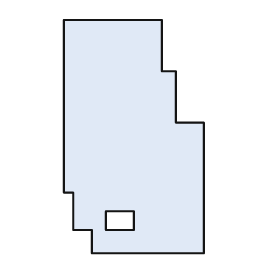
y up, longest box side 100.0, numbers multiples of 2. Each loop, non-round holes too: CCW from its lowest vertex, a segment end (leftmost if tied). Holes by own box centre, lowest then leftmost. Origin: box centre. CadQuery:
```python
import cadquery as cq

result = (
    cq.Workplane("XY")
    .moveTo(-18.0, -50.0)
    .lineTo(30.0, -50.0)
    .lineTo(30.0, 6.0)
    .lineTo(18.0, 6.0)
    .lineTo(18.0, 28.0)
    .lineTo(12.0, 28.0)
    .lineTo(12.0, 50.0)
    .lineTo(-30.0, 50.0)
    .lineTo(-30.0, -24.0)
    .lineTo(-26.0, -24.0)
    .lineTo(-26.0, -40.0)
    .lineTo(-18.0, -40.0)
    .close()
    .moveTo(-12.0, -40.0)
    .lineTo(0.0, -40.0)
    .lineTo(0.0, -32.0)
    .lineTo(-12.0, -32.0)
    .close()
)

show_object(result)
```